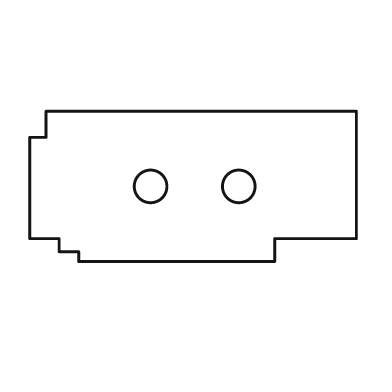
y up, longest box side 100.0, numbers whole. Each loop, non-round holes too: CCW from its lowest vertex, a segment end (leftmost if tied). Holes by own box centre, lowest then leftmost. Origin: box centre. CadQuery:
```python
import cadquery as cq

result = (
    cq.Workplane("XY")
    .moveTo(-35.0, -23.0)
    .lineTo(25.0, -23.0)
    .lineTo(25.0, -16.0)
    .lineTo(50.0, -16.0)
    .lineTo(50.0, 23.0)
    .lineTo(-45.0, 23.0)
    .lineTo(-45.0, 15.0)
    .lineTo(-50.0, 15.0)
    .lineTo(-50.0, -16.0)
    .lineTo(-41.0, -16.0)
    .lineTo(-41.0, -20.0)
    .lineTo(-35.0, -20.0)
    .close()
    .moveTo(-13.0, 0.0)
    .circle(5.0)
    .moveTo(14.0, 0.0)
    .circle(5.0)
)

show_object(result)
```